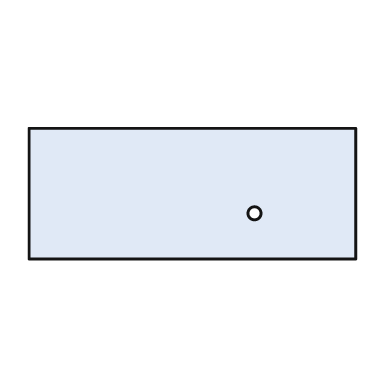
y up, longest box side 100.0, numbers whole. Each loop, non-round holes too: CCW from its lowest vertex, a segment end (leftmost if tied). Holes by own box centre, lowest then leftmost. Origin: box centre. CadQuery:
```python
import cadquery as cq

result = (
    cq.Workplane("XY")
    .moveTo(-50.0, -20.0)
    .lineTo(50.0, -20.0)
    .lineTo(50.0, 20.0)
    .lineTo(-50.0, 20.0)
    .close()
    .moveTo(19.0, -6.0)
    .circle(2.0)
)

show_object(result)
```